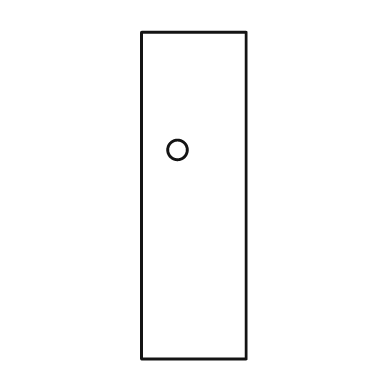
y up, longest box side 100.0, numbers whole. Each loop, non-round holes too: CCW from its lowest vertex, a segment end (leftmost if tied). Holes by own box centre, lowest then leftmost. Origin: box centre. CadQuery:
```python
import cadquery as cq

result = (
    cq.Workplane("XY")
    .moveTo(-16.0, -50.0)
    .lineTo(16.0, -50.0)
    .lineTo(16.0, 50.0)
    .lineTo(-16.0, 50.0)
    .close()
    .moveTo(-5.0, 14.0)
    .circle(3.0)
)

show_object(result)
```